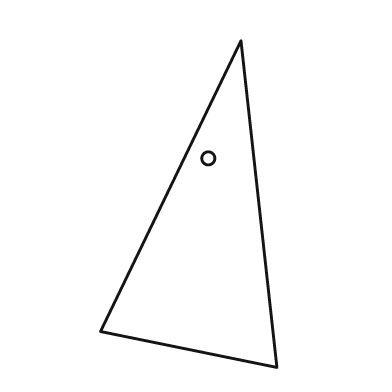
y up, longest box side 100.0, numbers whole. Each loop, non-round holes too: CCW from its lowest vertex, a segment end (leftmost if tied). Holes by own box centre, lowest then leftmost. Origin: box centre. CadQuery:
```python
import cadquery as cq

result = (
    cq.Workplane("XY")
    .moveTo(27.0, -50.0)
    .lineTo(16.0, 50.0)
    .lineTo(-27.0, -39.0)
    .close()
    .moveTo(6.0, 14.0)
    .circle(2.0)
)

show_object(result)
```